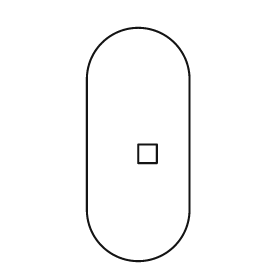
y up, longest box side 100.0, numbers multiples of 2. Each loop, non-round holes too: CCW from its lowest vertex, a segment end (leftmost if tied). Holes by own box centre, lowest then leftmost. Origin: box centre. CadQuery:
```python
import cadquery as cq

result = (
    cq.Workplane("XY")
    .moveTo(-22.0, -28.0)
    .threePointArc((0.0, -50.0), (22.0, -28.0))
    .lineTo(22.0, 28.0)
    .threePointArc((0.0, 50.0), (-22.0, 28.0))
    .close()
    .moveTo(0.0, -8.0)
    .lineTo(8.0, -8.0)
    .lineTo(8.0, 0.0)
    .lineTo(0.0, 0.0)
    .close()
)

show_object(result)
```